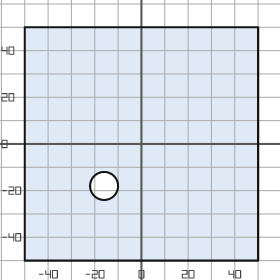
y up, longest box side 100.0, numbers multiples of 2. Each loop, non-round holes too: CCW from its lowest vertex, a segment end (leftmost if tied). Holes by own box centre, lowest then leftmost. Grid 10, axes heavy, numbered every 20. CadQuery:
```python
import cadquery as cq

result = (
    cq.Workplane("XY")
    .moveTo(-50.0, -50.0)
    .lineTo(50.0, -50.0)
    .lineTo(50.0, 50.0)
    .lineTo(-50.0, 50.0)
    .close()
    .moveTo(-16.0, -18.0)
    .circle(6.0)
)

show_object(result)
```